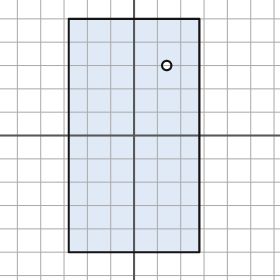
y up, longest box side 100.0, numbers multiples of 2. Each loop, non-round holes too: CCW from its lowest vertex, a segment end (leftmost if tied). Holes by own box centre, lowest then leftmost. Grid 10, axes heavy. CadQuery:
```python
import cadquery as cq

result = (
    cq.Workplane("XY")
    .moveTo(-28.0, -50.0)
    .lineTo(28.0, -50.0)
    .lineTo(28.0, 50.0)
    .lineTo(-28.0, 50.0)
    .close()
    .moveTo(14.0, 30.0)
    .circle(2.0)
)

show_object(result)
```